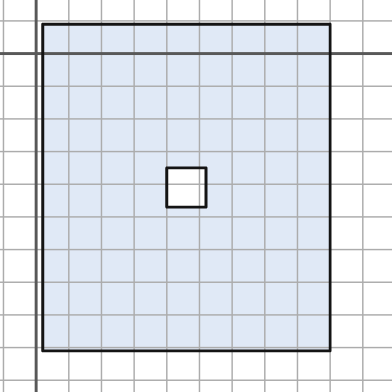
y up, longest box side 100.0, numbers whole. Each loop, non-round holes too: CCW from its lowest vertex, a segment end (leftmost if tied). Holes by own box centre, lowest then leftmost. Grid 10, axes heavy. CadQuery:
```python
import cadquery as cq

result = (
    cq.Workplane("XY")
    .moveTo(2.0, -91.0)
    .lineTo(90.0, -91.0)
    .lineTo(90.0, 9.0)
    .lineTo(2.0, 9.0)
    .close()
    .moveTo(40.0, -47.0)
    .lineTo(52.0, -47.0)
    .lineTo(52.0, -35.0)
    .lineTo(40.0, -35.0)
    .close()
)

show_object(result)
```